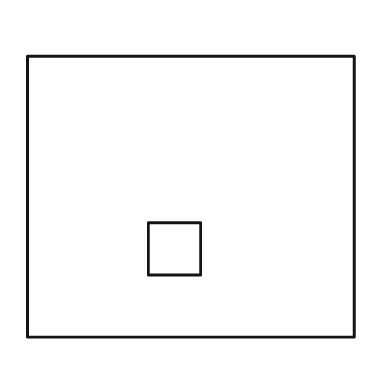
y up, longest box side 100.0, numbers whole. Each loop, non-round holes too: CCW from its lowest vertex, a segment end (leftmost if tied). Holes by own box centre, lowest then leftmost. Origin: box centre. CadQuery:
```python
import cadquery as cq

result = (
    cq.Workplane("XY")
    .moveTo(-50.0, -43.0)
    .lineTo(50.0, -43.0)
    .lineTo(50.0, 43.0)
    .lineTo(-50.0, 43.0)
    .close()
    .moveTo(-13.0, -24.0)
    .lineTo(3.0, -24.0)
    .lineTo(3.0, -8.0)
    .lineTo(-13.0, -8.0)
    .close()
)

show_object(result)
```